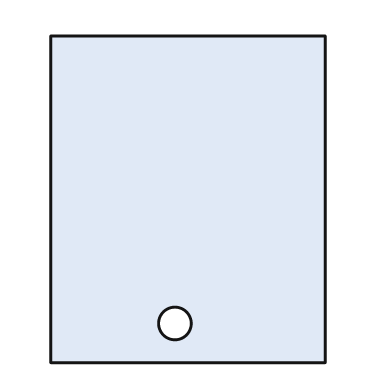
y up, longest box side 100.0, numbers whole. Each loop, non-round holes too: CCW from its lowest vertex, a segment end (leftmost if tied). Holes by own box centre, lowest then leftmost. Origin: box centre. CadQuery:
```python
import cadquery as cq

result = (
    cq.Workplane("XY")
    .moveTo(-42.0, -50.0)
    .lineTo(42.0, -50.0)
    .lineTo(42.0, 50.0)
    .lineTo(-42.0, 50.0)
    .close()
    .moveTo(-4.0, -38.0)
    .circle(5.0)
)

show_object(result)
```